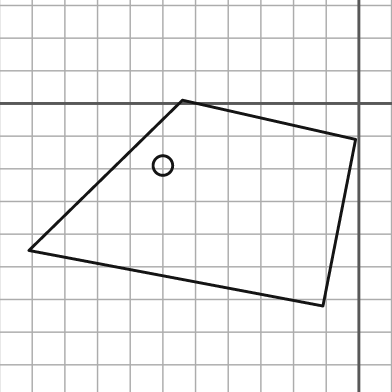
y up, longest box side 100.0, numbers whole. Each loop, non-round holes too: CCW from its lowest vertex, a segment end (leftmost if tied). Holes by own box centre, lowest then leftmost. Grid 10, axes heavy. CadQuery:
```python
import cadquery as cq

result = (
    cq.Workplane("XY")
    .moveTo(-11.0, -62.0)
    .lineTo(-1.0, -11.0)
    .lineTo(-54.0, 1.0)
    .lineTo(-101.0, -45.0)
    .close()
    .moveTo(-60.0, -19.0)
    .circle(3.0)
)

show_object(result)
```